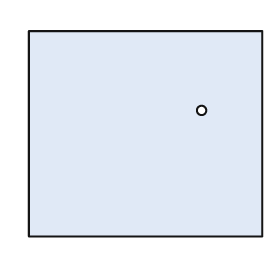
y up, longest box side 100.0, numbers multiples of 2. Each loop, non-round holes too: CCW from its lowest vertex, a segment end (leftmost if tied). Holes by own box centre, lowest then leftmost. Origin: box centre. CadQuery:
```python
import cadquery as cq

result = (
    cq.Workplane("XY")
    .moveTo(-50.0, -44.0)
    .lineTo(50.0, -44.0)
    .lineTo(50.0, 44.0)
    .lineTo(-50.0, 44.0)
    .close()
    .moveTo(24.0, 10.0)
    .circle(2.0)
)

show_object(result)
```